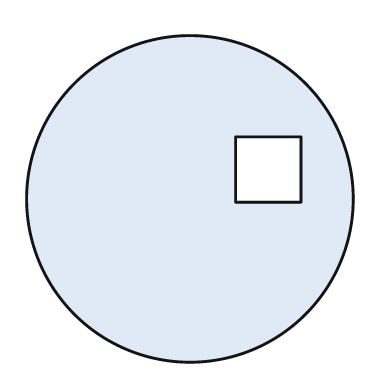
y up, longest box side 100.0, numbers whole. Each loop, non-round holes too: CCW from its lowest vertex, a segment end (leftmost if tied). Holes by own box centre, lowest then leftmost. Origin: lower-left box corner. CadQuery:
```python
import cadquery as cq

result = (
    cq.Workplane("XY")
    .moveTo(50.0, 50.0)
    .circle(50.0)
    .moveTo(64.0, 49.0)
    .lineTo(84.0, 49.0)
    .lineTo(84.0, 69.0)
    .lineTo(64.0, 69.0)
    .close()
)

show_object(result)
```